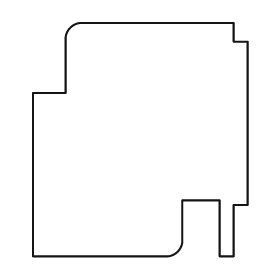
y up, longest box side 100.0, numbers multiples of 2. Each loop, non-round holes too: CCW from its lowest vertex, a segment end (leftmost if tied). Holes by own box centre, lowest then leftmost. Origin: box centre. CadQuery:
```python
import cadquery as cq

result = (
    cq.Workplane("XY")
    .moveTo(-46.0, -50.0)
    .lineTo(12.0, -50.0)
    .threePointArc((16.0, -48.0), (18.0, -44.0))
    .lineTo(18.0, -26.0)
    .lineTo(34.0, -26.0)
    .lineTo(34.0, -50.0)
    .lineTo(40.0, -50.0)
    .lineTo(40.0, -28.0)
    .lineTo(46.0, -28.0)
    .lineTo(46.0, 42.0)
    .lineTo(40.0, 42.0)
    .lineTo(40.0, 50.0)
    .lineTo(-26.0, 50.0)
    .threePointArc((-30.0, 48.0), (-32.0, 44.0))
    .lineTo(-32.0, 20.0)
    .lineTo(-46.0, 20.0)
    .close()
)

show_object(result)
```